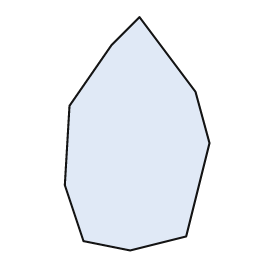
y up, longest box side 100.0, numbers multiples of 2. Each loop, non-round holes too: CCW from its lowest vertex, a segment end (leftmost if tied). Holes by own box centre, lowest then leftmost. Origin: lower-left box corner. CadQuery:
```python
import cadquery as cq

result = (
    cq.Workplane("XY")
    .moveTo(28.0, 0.0)
    .lineTo(52.0, 6.0)
    .lineTo(62.0, 46.0)
    .lineTo(56.0, 68.0)
    .lineTo(32.0, 100.0)
    .lineTo(20.0, 88.0)
    .lineTo(2.0, 62.0)
    .lineTo(0.0, 28.0)
    .lineTo(8.0, 4.0)
    .close()
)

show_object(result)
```